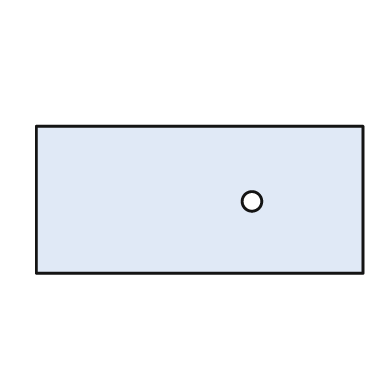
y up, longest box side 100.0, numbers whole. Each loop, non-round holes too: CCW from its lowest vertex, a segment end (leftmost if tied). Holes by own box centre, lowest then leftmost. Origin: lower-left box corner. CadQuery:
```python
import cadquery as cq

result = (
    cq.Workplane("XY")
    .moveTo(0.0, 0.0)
    .lineTo(100.0, 0.0)
    .lineTo(100.0, 45.0)
    .lineTo(0.0, 45.0)
    .close()
    .moveTo(66.0, 22.0)
    .circle(3.0)
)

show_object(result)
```